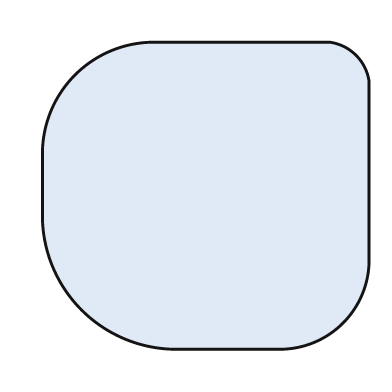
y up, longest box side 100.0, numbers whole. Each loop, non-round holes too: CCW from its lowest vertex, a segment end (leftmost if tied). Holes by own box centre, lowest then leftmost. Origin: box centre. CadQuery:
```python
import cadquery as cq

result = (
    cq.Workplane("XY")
    .moveTo(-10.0, -47.0)
    .lineTo(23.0, -47.0)
    .threePointArc((42.0, -39.0), (50.0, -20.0))
    .lineTo(50.0, 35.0)
    .threePointArc((46.0, 43.0), (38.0, 47.0))
    .lineTo(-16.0, 47.0)
    .threePointArc((-40.0, 37.0), (-50.0, 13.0))
    .lineTo(-50.0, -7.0)
    .threePointArc((-38.0, -35.0), (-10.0, -47.0))
    .close()
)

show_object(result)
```